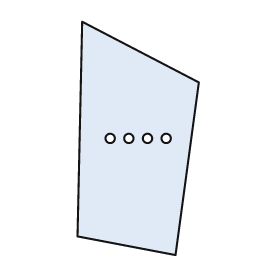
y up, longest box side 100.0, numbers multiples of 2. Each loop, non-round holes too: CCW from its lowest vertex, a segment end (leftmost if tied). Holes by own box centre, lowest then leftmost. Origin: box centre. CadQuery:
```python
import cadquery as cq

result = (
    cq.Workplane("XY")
    .moveTo(16.0, -50.0)
    .lineTo(26.0, 24.0)
    .lineTo(-24.0, 50.0)
    .lineTo(-26.0, -42.0)
    .close()
    .moveTo(-12.0, 0.0)
    .circle(2.0)
    .moveTo(-4.0, 0.0)
    .circle(2.0)
    .moveTo(4.0, 0.0)
    .circle(2.0)
    .moveTo(12.0, 0.0)
    .circle(2.0)
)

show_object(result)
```